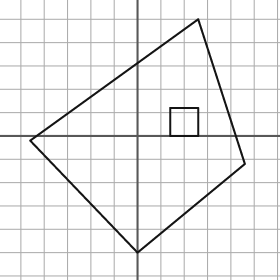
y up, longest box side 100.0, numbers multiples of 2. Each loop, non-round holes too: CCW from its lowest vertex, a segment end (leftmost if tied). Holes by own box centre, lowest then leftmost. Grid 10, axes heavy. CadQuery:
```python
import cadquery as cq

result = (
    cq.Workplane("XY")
    .moveTo(0.0, -50.0)
    .lineTo(46.0, -12.0)
    .lineTo(26.0, 50.0)
    .lineTo(-46.0, -2.0)
    .close()
    .moveTo(14.0, 0.0)
    .lineTo(26.0, 0.0)
    .lineTo(26.0, 12.0)
    .lineTo(14.0, 12.0)
    .close()
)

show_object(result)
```